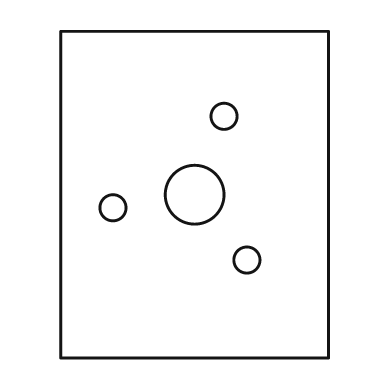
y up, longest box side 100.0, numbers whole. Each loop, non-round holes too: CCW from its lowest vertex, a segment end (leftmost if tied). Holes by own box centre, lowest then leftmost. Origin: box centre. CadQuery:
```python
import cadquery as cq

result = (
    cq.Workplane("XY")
    .moveTo(-41.0, -50.0)
    .lineTo(41.0, -50.0)
    .lineTo(41.0, 50.0)
    .lineTo(-41.0, 50.0)
    .close()
    .moveTo(16.0, -20.0)
    .circle(4.0)
    .moveTo(-25.0, -4.0)
    .circle(4.0)
    .moveTo(0.0, 0.0)
    .circle(9.0)
    .moveTo(9.0, 24.0)
    .circle(4.0)
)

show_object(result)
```